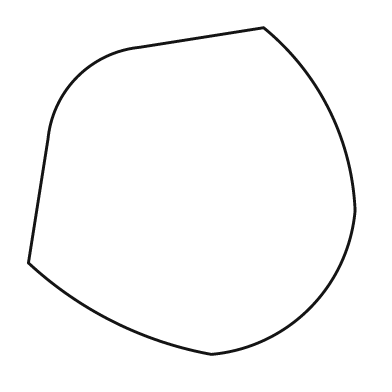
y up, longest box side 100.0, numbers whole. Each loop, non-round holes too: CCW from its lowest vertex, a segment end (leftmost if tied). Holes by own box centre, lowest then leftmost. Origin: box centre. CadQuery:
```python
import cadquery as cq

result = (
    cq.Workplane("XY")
    .moveTo(6.0, -50.0)
    .threePointArc((36.0, -36.0), (50.0, -6.0))
    .threePointArc((42.0, 25.0), (22.0, 50.0))
    .lineTo(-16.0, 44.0)
    .threePointArc((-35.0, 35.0), (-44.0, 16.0))
    .lineTo(-50.0, -22.0)
    .threePointArc((-24.0, -40.0), (6.0, -50.0))
    .close()
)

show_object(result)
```